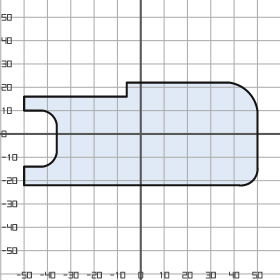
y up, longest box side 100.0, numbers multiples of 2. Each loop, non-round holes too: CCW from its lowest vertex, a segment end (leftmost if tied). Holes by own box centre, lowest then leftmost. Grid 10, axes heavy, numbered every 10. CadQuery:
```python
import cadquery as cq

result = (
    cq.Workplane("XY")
    .moveTo(-50.0, -22.0)
    .lineTo(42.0, -22.0)
    .threePointArc((48.0, -20.0), (50.0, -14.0))
    .lineTo(50.0, 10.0)
    .threePointArc((46.0, 18.0), (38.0, 22.0))
    .lineTo(-6.0, 22.0)
    .lineTo(-6.0, 16.0)
    .lineTo(-50.0, 16.0)
    .lineTo(-50.0, 10.0)
    .lineTo(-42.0, 10.0)
    .threePointArc((-38.0, 8.0), (-36.0, 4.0))
    .lineTo(-36.0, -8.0)
    .threePointArc((-38.0, -12.0), (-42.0, -14.0))
    .lineTo(-50.0, -14.0)
    .close()
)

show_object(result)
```